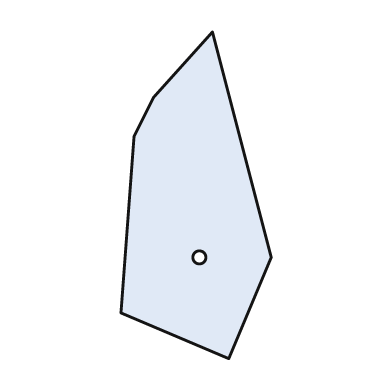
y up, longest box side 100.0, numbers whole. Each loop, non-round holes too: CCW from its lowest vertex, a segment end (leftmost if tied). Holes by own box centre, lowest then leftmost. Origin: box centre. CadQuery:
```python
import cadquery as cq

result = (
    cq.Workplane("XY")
    .moveTo(10.0, -50.0)
    .lineTo(23.0, -19.0)
    .lineTo(5.0, 50.0)
    .lineTo(-13.0, 30.0)
    .lineTo(-19.0, 18.0)
    .lineTo(-23.0, -36.0)
    .close()
    .moveTo(1.0, -19.0)
    .circle(2.0)
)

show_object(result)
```